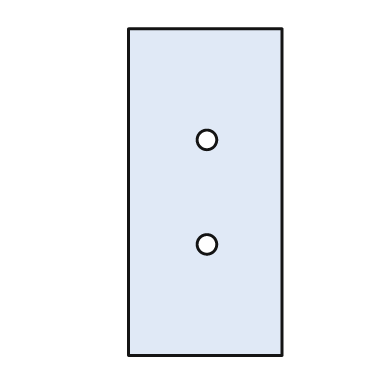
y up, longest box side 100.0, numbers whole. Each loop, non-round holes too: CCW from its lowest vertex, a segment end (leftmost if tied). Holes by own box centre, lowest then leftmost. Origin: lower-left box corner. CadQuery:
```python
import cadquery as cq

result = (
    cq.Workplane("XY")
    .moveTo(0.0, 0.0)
    .lineTo(47.0, 0.0)
    .lineTo(47.0, 100.0)
    .lineTo(0.0, 100.0)
    .close()
    .moveTo(24.0, 34.0)
    .circle(3.0)
    .moveTo(24.0, 66.0)
    .circle(3.0)
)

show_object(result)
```